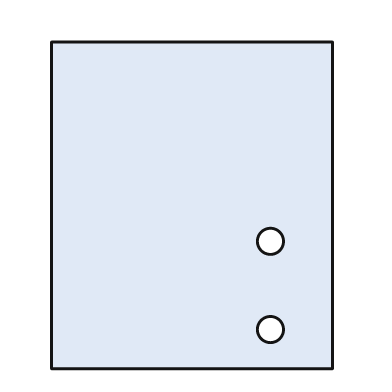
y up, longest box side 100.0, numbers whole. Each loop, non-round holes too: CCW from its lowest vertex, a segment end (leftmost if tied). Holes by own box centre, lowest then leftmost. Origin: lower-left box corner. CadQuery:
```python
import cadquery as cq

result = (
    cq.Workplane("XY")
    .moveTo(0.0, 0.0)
    .lineTo(86.0, 0.0)
    .lineTo(86.0, 100.0)
    .lineTo(0.0, 100.0)
    .close()
    .moveTo(67.0, 12.0)
    .circle(4.0)
    .moveTo(67.0, 39.0)
    .circle(4.0)
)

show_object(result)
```